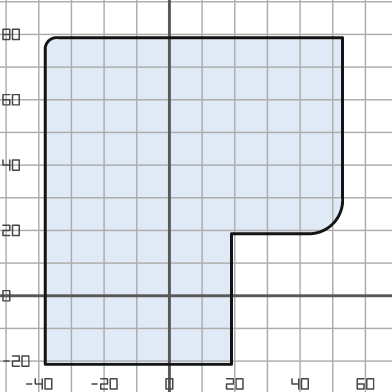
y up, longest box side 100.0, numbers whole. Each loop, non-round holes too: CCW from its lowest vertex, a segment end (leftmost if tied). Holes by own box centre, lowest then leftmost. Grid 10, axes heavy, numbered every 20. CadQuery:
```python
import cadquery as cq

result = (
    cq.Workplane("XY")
    .moveTo(-38.0, -21.0)
    .lineTo(19.0, -21.0)
    .lineTo(19.0, 19.0)
    .lineTo(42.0, 19.0)
    .threePointArc((50.0, 22.0), (53.0, 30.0))
    .lineTo(53.0, 79.0)
    .lineTo(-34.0, 79.0)
    .threePointArc((-37.0, 78.0), (-38.0, 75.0))
    .close()
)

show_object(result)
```